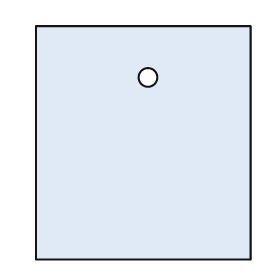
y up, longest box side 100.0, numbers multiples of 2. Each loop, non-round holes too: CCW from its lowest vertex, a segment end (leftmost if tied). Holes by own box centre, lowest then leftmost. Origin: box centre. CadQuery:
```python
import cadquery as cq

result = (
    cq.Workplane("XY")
    .moveTo(-46.0, -50.0)
    .lineTo(46.0, -50.0)
    .lineTo(46.0, 50.0)
    .lineTo(-46.0, 50.0)
    .close()
    .moveTo(2.0, 28.0)
    .circle(4.0)
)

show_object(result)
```